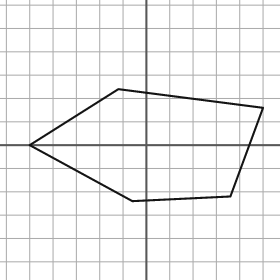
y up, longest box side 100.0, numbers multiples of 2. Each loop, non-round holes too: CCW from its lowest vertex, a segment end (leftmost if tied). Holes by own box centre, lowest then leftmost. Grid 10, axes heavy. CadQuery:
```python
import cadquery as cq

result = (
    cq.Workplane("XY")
    .moveTo(-6.0, -24.0)
    .lineTo(36.0, -22.0)
    .lineTo(50.0, 16.0)
    .lineTo(-12.0, 24.0)
    .lineTo(-50.0, 0.0)
    .close()
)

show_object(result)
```